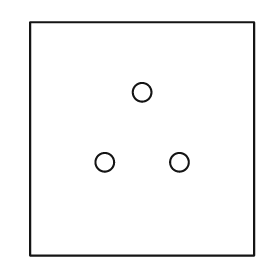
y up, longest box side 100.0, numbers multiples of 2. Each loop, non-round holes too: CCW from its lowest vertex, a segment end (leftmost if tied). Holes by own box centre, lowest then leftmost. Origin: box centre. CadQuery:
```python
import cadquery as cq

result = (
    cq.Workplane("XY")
    .moveTo(-48.0, -50.0)
    .lineTo(48.0, -50.0)
    .lineTo(48.0, 50.0)
    .lineTo(-48.0, 50.0)
    .close()
    .moveTo(-16.0, -10.0)
    .circle(4.0)
    .moveTo(16.0, -10.0)
    .circle(4.0)
    .moveTo(0.0, 20.0)
    .circle(4.0)
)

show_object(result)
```